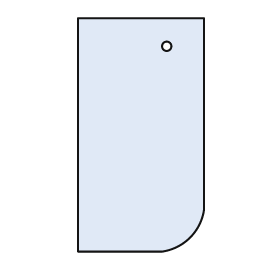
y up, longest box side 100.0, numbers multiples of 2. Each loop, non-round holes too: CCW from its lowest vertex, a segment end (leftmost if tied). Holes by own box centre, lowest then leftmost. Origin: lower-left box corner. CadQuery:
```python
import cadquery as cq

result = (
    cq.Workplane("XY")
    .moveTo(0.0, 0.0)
    .lineTo(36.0, 0.0)
    .threePointArc((48.0, 6.0), (54.0, 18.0))
    .lineTo(54.0, 100.0)
    .lineTo(0.0, 100.0)
    .close()
    .moveTo(38.0, 88.0)
    .circle(2.0)
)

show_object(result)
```